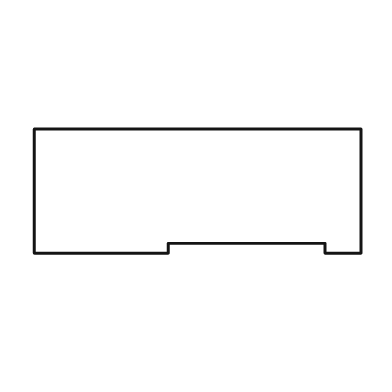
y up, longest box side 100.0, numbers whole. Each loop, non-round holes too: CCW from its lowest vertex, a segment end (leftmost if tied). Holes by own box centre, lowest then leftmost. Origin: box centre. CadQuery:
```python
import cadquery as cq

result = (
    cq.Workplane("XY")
    .moveTo(-50.0, -19.0)
    .lineTo(-9.0, -19.0)
    .lineTo(-9.0, -16.0)
    .lineTo(39.0, -16.0)
    .lineTo(39.0, -19.0)
    .lineTo(50.0, -19.0)
    .lineTo(50.0, 19.0)
    .lineTo(-50.0, 19.0)
    .close()
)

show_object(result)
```